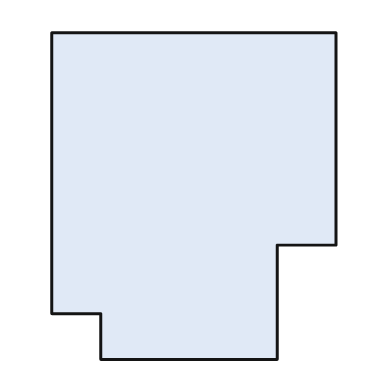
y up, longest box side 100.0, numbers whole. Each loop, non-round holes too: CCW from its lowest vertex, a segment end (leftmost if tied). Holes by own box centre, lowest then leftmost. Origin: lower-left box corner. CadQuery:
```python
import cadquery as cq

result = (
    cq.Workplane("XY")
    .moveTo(15.0, 0.0)
    .lineTo(69.0, 0.0)
    .lineTo(69.0, 35.0)
    .lineTo(87.0, 35.0)
    .lineTo(87.0, 100.0)
    .lineTo(0.0, 100.0)
    .lineTo(0.0, 14.0)
    .lineTo(15.0, 14.0)
    .close()
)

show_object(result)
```